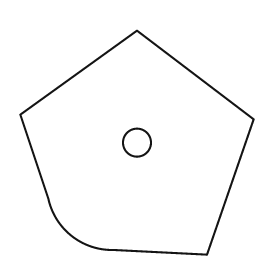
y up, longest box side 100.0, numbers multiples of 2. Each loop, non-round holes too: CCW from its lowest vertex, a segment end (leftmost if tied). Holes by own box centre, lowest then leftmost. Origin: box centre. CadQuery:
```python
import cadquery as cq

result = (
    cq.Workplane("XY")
    .moveTo(30.0, -48.0)
    .lineTo(50.0, 10.0)
    .lineTo(0.0, 48.0)
    .lineTo(-50.0, 12.0)
    .lineTo(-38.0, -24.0)
    .threePointArc((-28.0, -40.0), (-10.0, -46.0))
    .close()
    .moveTo(0.0, 0.0)
    .circle(6.0)
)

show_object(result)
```